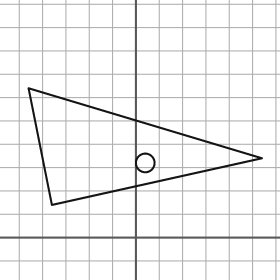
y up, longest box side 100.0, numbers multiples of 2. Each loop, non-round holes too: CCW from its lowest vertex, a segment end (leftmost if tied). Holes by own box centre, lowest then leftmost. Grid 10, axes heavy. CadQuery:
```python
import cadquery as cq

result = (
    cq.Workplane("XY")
    .moveTo(-36.0, 14.0)
    .lineTo(54.0, 34.0)
    .lineTo(-46.0, 64.0)
    .close()
    .moveTo(4.0, 32.0)
    .circle(4.0)
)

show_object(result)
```